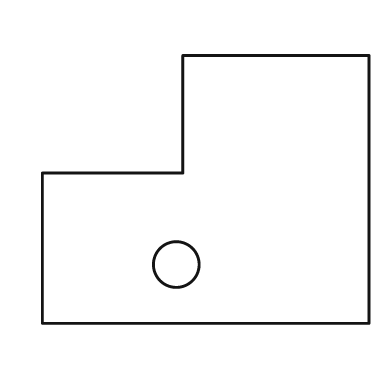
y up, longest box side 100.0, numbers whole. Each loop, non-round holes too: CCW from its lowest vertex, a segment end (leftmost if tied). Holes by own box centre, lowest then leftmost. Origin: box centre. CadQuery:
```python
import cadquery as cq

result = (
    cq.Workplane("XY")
    .moveTo(-50.0, -41.0)
    .lineTo(50.0, -41.0)
    .lineTo(50.0, 41.0)
    .lineTo(-7.0, 41.0)
    .lineTo(-7.0, 5.0)
    .lineTo(-50.0, 5.0)
    .close()
    .moveTo(-9.0, -23.0)
    .circle(7.0)
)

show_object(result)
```